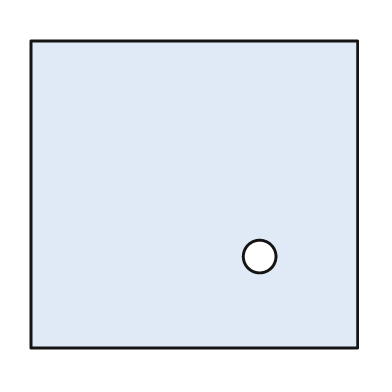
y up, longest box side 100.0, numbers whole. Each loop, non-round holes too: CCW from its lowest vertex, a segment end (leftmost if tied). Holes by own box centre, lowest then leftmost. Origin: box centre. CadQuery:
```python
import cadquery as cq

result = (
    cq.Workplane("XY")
    .moveTo(-50.0, -47.0)
    .lineTo(50.0, -47.0)
    .lineTo(50.0, 47.0)
    .lineTo(-50.0, 47.0)
    .close()
    .moveTo(20.0, -19.0)
    .circle(5.0)
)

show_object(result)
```